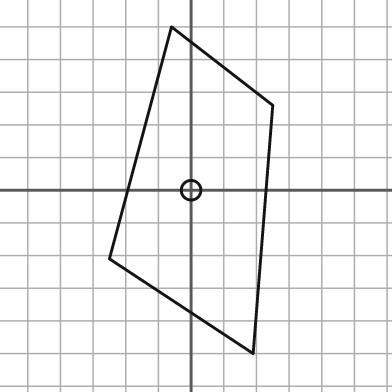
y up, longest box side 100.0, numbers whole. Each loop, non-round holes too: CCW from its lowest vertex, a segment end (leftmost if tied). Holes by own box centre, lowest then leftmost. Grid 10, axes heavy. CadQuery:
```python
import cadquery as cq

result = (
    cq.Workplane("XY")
    .moveTo(19.0, -50.0)
    .lineTo(25.0, 26.0)
    .lineTo(-6.0, 50.0)
    .lineTo(-25.0, -21.0)
    .close()
    .moveTo(0.0, 0.0)
    .circle(3.0)
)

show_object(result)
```